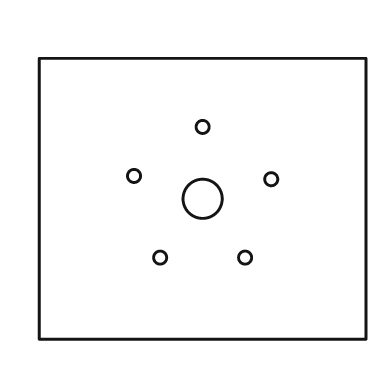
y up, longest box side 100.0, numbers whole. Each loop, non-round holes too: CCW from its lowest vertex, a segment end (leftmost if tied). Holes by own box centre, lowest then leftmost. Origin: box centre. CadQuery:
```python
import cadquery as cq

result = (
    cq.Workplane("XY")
    .moveTo(-50.0, -43.0)
    .lineTo(50.0, -43.0)
    .lineTo(50.0, 43.0)
    .lineTo(-50.0, 43.0)
    .close()
    .moveTo(-13.0, -18.0)
    .circle(2.0)
    .moveTo(13.0, -18.0)
    .circle(2.0)
    .moveTo(0.0, 0.0)
    .circle(6.0)
    .moveTo(21.0, 6.0)
    .circle(2.0)
    .moveTo(-21.0, 7.0)
    .circle(2.0)
    .moveTo(0.0, 22.0)
    .circle(2.0)
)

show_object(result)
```